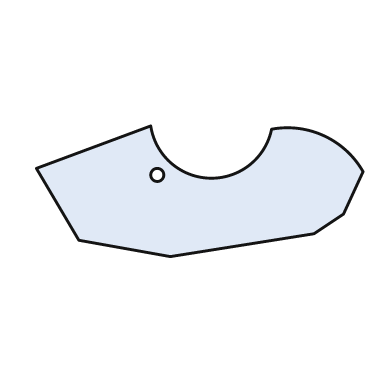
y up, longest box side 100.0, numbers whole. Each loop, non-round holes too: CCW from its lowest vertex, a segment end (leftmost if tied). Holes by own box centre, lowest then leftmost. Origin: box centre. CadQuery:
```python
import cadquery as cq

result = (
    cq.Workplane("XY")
    .moveTo(-9.0, -20.0)
    .lineTo(35.0, -13.0)
    .lineTo(44.0, -7.0)
    .lineTo(50.0, 6.0)
    .threePointArc((38.0, 17.0), (22.0, 19.0))
    .threePointArc((3.0, 4.0), (-15.0, 20.0))
    .lineTo(-50.0, 7.0)
    .lineTo(-37.0, -15.0)
    .close()
    .moveTo(-13.0, 5.0)
    .circle(2.0)
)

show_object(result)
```